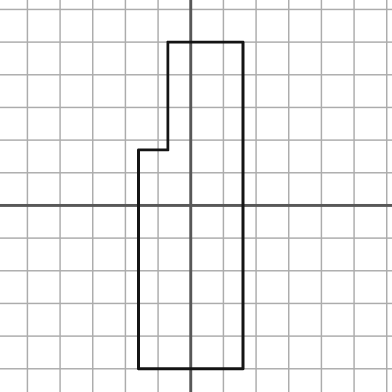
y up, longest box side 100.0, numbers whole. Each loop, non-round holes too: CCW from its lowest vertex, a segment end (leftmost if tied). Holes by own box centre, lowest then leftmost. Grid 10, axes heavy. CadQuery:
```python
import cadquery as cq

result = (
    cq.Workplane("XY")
    .moveTo(-16.0, -50.0)
    .lineTo(16.0, -50.0)
    .lineTo(16.0, 50.0)
    .lineTo(-7.0, 50.0)
    .lineTo(-7.0, 17.0)
    .lineTo(-16.0, 17.0)
    .close()
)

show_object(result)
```